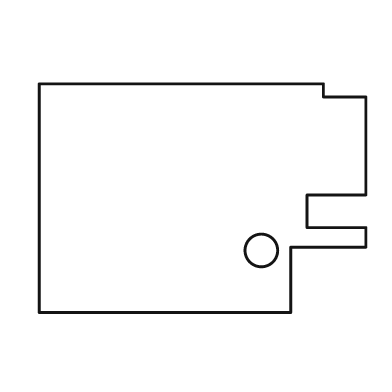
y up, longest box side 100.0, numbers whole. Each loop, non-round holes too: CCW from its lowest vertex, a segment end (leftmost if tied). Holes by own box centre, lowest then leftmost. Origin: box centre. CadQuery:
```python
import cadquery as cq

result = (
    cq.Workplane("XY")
    .moveTo(-50.0, -35.0)
    .lineTo(27.0, -35.0)
    .lineTo(27.0, -15.0)
    .lineTo(50.0, -15.0)
    .lineTo(50.0, -9.0)
    .lineTo(32.0, -9.0)
    .lineTo(32.0, 1.0)
    .lineTo(50.0, 1.0)
    .lineTo(50.0, 31.0)
    .lineTo(37.0, 31.0)
    .lineTo(37.0, 35.0)
    .lineTo(-50.0, 35.0)
    .close()
    .moveTo(18.0, -16.0)
    .circle(5.0)
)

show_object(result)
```